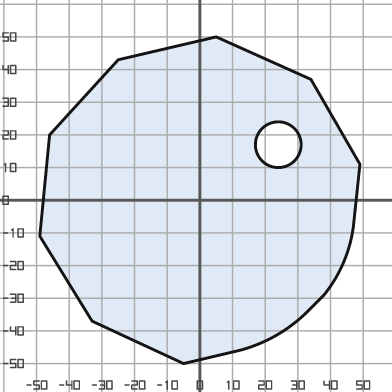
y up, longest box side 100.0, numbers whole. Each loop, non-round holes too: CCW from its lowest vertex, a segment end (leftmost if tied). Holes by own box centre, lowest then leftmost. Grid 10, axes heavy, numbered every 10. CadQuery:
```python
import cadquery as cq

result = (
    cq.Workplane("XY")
    .moveTo(-5.0, -50.0)
    .lineTo(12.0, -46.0)
    .threePointArc((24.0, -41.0), (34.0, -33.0))
    .lineTo(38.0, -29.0)
    .threePointArc((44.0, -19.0), (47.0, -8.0))
    .lineTo(49.0, 11.0)
    .lineTo(34.0, 37.0)
    .lineTo(5.0, 50.0)
    .lineTo(-25.0, 43.0)
    .lineTo(-46.0, 20.0)
    .lineTo(-49.0, -11.0)
    .lineTo(-33.0, -37.0)
    .close()
    .moveTo(24.0, 17.0)
    .circle(7.0)
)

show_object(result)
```